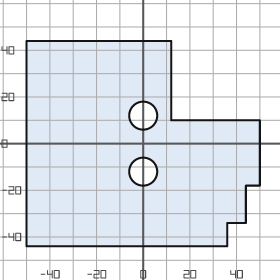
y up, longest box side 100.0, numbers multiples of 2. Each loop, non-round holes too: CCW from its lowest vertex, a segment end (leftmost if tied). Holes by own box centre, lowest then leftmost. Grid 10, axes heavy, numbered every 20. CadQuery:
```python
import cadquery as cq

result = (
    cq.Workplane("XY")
    .moveTo(-50.0, -44.0)
    .lineTo(36.0, -44.0)
    .lineTo(36.0, -34.0)
    .lineTo(44.0, -34.0)
    .lineTo(44.0, -18.0)
    .lineTo(50.0, -18.0)
    .lineTo(50.0, 10.0)
    .lineTo(12.0, 10.0)
    .lineTo(12.0, 44.0)
    .lineTo(-50.0, 44.0)
    .close()
    .moveTo(0.0, -12.0)
    .circle(6.0)
    .moveTo(0.0, 12.0)
    .circle(6.0)
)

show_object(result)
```